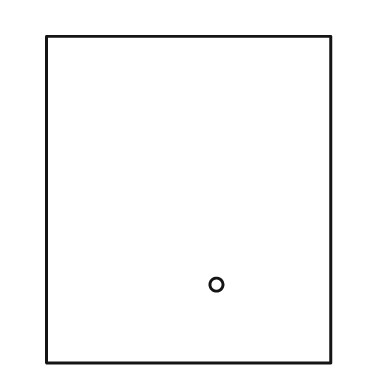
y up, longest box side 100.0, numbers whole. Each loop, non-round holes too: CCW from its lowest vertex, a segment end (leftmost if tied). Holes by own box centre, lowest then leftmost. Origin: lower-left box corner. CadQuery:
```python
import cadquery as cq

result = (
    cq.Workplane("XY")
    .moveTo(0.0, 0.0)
    .lineTo(87.0, 0.0)
    .lineTo(87.0, 100.0)
    .lineTo(0.0, 100.0)
    .close()
    .moveTo(52.0, 24.0)
    .circle(2.0)
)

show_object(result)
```